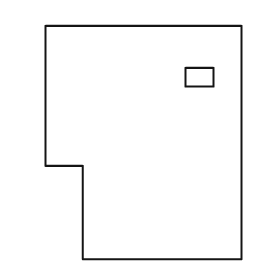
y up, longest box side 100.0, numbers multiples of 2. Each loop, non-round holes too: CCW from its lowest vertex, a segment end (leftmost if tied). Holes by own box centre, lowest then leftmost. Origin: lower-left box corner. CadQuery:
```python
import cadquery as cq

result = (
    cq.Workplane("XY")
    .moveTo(16.0, 0.0)
    .lineTo(84.0, 0.0)
    .lineTo(84.0, 100.0)
    .lineTo(0.0, 100.0)
    .lineTo(0.0, 40.0)
    .lineTo(16.0, 40.0)
    .close()
    .moveTo(60.0, 74.0)
    .lineTo(72.0, 74.0)
    .lineTo(72.0, 82.0)
    .lineTo(60.0, 82.0)
    .close()
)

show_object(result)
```